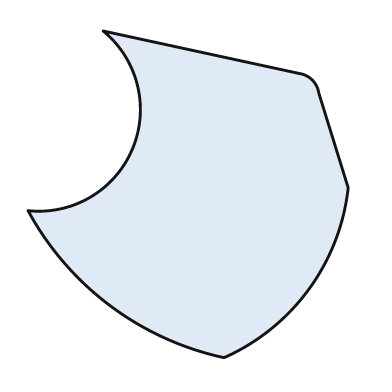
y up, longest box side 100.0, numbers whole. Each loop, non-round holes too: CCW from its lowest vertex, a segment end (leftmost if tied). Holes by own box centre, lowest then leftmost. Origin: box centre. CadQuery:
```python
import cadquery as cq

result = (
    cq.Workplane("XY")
    .moveTo(11.0, -50.0)
    .threePointArc((37.0, -29.0), (49.0, 2.0))
    .lineTo(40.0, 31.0)
    .threePointArc((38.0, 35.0), (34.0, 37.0))
    .lineTo(-26.0, 50.0)
    .threePointArc((-17.0, 14.0), (-49.0, -5.0))
    .threePointArc((-24.0, -34.0), (11.0, -50.0))
    .close()
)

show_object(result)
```